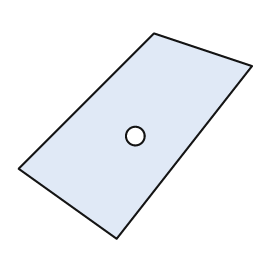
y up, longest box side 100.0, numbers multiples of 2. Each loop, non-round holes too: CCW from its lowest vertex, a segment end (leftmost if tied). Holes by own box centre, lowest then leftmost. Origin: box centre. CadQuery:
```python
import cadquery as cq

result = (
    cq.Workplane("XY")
    .moveTo(-8.0, -44.0)
    .lineTo(50.0, 30.0)
    .lineTo(8.0, 44.0)
    .lineTo(-50.0, -14.0)
    .close()
    .moveTo(0.0, 0.0)
    .circle(4.0)
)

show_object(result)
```